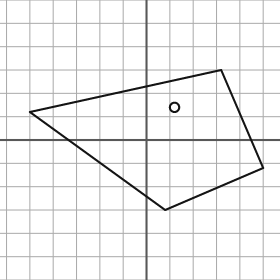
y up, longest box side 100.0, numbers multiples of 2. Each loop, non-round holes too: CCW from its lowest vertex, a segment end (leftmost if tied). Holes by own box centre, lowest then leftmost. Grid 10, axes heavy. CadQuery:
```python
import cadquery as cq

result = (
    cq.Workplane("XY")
    .moveTo(8.0, -30.0)
    .lineTo(50.0, -12.0)
    .lineTo(32.0, 30.0)
    .lineTo(-50.0, 12.0)
    .close()
    .moveTo(12.0, 14.0)
    .circle(2.0)
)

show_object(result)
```